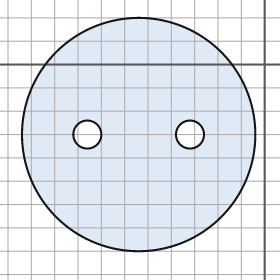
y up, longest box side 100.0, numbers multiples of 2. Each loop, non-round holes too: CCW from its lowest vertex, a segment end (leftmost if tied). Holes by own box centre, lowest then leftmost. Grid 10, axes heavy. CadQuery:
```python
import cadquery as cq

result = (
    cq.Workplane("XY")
    .moveTo(-54.0, -30.0)
    .circle(50.0)
    .moveTo(-76.0, -30.0)
    .circle(6.0)
    .moveTo(-32.0, -30.0)
    .circle(6.0)
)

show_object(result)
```